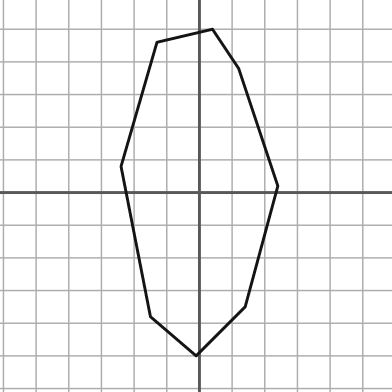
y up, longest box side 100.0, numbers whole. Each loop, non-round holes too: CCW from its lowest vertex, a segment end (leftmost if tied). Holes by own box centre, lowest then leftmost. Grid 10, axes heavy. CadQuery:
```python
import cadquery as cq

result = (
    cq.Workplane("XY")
    .moveTo(-1.0, -50.0)
    .lineTo(14.0, -35.0)
    .lineTo(24.0, 2.0)
    .lineTo(12.0, 38.0)
    .lineTo(4.0, 50.0)
    .lineTo(-13.0, 46.0)
    .lineTo(-24.0, 8.0)
    .lineTo(-15.0, -38.0)
    .close()
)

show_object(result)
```